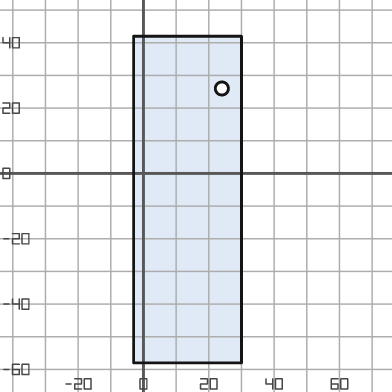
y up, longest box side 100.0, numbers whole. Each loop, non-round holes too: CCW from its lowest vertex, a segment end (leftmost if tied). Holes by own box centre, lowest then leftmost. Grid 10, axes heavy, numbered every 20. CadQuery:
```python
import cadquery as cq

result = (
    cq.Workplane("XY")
    .moveTo(-3.0, -58.0)
    .lineTo(30.0, -58.0)
    .lineTo(30.0, 42.0)
    .lineTo(-3.0, 42.0)
    .close()
    .moveTo(24.0, 26.0)
    .circle(2.0)
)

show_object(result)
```